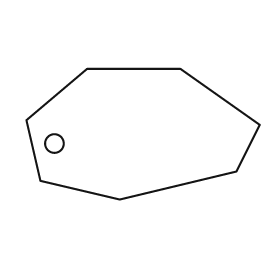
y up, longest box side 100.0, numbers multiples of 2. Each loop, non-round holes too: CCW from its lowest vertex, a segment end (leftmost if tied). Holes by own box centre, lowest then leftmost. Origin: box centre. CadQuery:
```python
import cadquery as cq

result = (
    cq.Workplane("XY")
    .moveTo(-10.0, -28.0)
    .lineTo(40.0, -16.0)
    .lineTo(50.0, 4.0)
    .lineTo(16.0, 28.0)
    .lineTo(-24.0, 28.0)
    .lineTo(-50.0, 6.0)
    .lineTo(-44.0, -20.0)
    .close()
    .moveTo(-38.0, -4.0)
    .circle(4.0)
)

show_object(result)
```